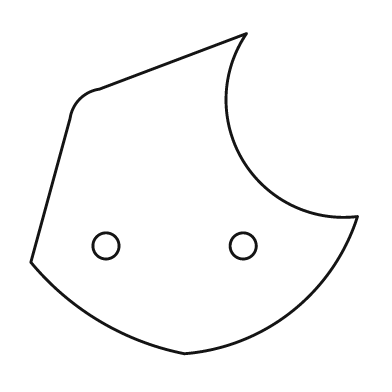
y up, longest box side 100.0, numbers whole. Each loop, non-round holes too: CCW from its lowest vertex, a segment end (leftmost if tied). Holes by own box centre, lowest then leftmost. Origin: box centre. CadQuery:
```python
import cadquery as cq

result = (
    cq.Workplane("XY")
    .moveTo(-3.0, -49.0)
    .threePointArc((30.0, -36.0), (50.0, -7.0))
    .threePointArc((15.0, 10.0), (16.0, 49.0))
    .lineTo(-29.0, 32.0)
    .threePointArc((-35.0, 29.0), (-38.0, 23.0))
    .lineTo(-50.0, -21.0)
    .threePointArc((-29.0, -39.0), (-3.0, -49.0))
    .close()
    .moveTo(-27.0, -16.0)
    .circle(4.0)
    .moveTo(15.0, -16.0)
    .circle(4.0)
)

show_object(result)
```